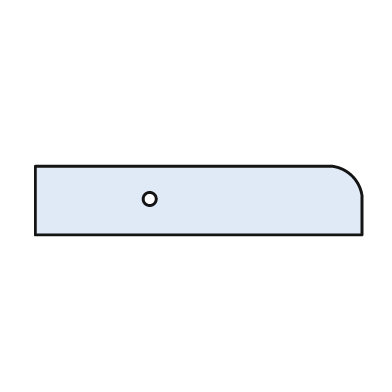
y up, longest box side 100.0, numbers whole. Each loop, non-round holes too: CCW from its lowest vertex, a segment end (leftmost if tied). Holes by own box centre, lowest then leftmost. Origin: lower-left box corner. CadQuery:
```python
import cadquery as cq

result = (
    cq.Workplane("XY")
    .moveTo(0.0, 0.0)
    .lineTo(100.0, 0.0)
    .lineTo(100.0, 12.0)
    .threePointArc((97.0, 18.0), (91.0, 21.0))
    .lineTo(0.0, 21.0)
    .close()
    .moveTo(35.0, 11.0)
    .circle(2.0)
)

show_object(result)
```